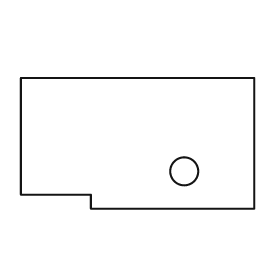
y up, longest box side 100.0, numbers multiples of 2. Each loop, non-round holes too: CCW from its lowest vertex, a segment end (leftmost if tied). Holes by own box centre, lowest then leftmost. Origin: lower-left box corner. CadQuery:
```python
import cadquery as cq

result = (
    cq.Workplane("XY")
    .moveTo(30.0, 0.0)
    .lineTo(100.0, 0.0)
    .lineTo(100.0, 56.0)
    .lineTo(0.0, 56.0)
    .lineTo(0.0, 6.0)
    .lineTo(30.0, 6.0)
    .close()
    .moveTo(70.0, 16.0)
    .circle(6.0)
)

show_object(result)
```